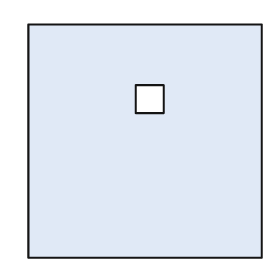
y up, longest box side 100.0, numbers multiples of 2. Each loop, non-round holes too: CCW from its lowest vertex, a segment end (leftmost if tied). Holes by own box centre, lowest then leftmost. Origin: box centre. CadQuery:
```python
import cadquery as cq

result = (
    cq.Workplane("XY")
    .moveTo(-50.0, -50.0)
    .lineTo(50.0, -50.0)
    .lineTo(50.0, 50.0)
    .lineTo(-50.0, 50.0)
    .close()
    .moveTo(-4.0, 12.0)
    .lineTo(8.0, 12.0)
    .lineTo(8.0, 24.0)
    .lineTo(-4.0, 24.0)
    .close()
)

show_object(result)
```